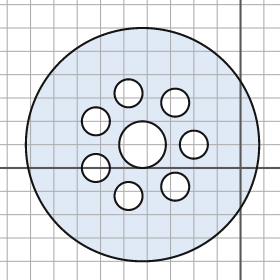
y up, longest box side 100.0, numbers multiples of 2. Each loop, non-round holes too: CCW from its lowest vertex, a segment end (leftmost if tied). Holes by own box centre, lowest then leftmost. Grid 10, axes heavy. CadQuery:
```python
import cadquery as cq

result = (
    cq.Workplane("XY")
    .moveTo(-42.0, 10.0)
    .circle(50.0)
    .moveTo(-48.0, -12.0)
    .circle(6.0)
    .moveTo(-28.0, -8.0)
    .circle(6.0)
    .moveTo(-62.0, 0.0)
    .circle(6.0)
    .moveTo(-42.0, 10.0)
    .circle(10.0)
    .moveTo(-20.0, 10.0)
    .circle(6.0)
    .moveTo(-62.0, 20.0)
    .circle(6.0)
    .moveTo(-28.0, 28.0)
    .circle(6.0)
    .moveTo(-48.0, 32.0)
    .circle(6.0)
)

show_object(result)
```